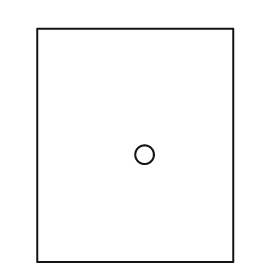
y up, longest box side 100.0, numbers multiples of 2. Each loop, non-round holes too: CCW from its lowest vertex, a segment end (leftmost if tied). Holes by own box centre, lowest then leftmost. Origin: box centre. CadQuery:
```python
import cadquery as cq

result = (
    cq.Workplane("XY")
    .moveTo(-42.0, -50.0)
    .lineTo(42.0, -50.0)
    .lineTo(42.0, 50.0)
    .lineTo(-42.0, 50.0)
    .close()
    .moveTo(4.0, -4.0)
    .circle(4.0)
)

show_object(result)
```